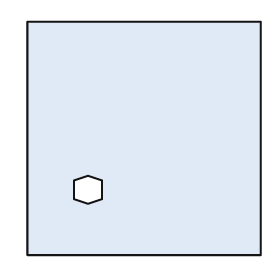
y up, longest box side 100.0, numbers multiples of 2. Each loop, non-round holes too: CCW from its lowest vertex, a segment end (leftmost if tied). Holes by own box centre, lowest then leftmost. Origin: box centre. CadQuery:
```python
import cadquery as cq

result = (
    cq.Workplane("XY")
    .moveTo(-50.0, -50.0)
    .lineTo(50.0, -50.0)
    .lineTo(50.0, 50.0)
    .lineTo(-50.0, 50.0)
    .close()
    .moveTo(-24.0, -28.0)
    .lineTo(-18.0, -26.0)
    .lineTo(-18.0, -18.0)
    .lineTo(-24.0, -16.0)
    .lineTo(-30.0, -18.0)
    .lineTo(-30.0, -26.0)
    .close()
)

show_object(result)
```